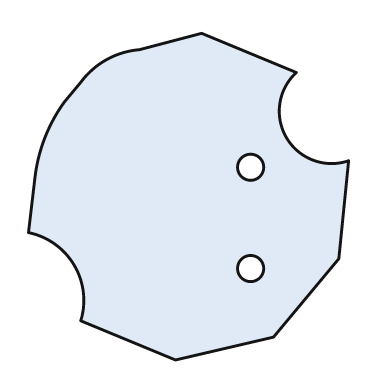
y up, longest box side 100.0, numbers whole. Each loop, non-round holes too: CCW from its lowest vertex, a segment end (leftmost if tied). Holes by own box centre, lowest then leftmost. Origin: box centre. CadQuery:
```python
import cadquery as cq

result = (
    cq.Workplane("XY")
    .moveTo(-4.0, -50.0)
    .lineTo(26.0, -43.0)
    .lineTo(46.0, -19.0)
    .lineTo(49.0, 11.0)
    .threePointArc((30.0, 18.0), (33.0, 38.0))
    .lineTo(4.0, 50.0)
    .lineTo(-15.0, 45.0)
    .threePointArc((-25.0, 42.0), (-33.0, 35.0))
    .lineTo(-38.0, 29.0)
    .threePointArc((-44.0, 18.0), (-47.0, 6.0))
    .lineTo(-49.0, -11.0)
    .threePointArc((-35.0, -21.0), (-33.0, -38.0))
    .close()
    .moveTo(19.0, -22.0)
    .circle(4.0)
    .moveTo(19.0, 9.0)
    .circle(4.0)
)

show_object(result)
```